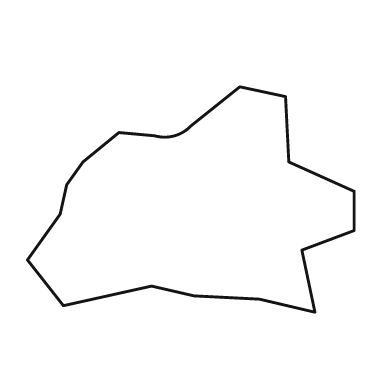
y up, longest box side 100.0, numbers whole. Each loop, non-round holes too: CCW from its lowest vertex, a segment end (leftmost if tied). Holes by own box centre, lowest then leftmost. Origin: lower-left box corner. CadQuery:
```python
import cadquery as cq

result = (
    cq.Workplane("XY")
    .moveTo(88.0, 0.0)
    .lineTo(84.0, 19.0)
    .lineTo(100.0, 25.0)
    .lineTo(100.0, 37.0)
    .lineTo(80.0, 46.0)
    .lineTo(79.0, 66.0)
    .lineTo(65.0, 69.0)
    .lineTo(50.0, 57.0)
    .threePointArc((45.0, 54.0), (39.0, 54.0))
    .lineTo(28.0, 55.0)
    .lineTo(17.0, 46.0)
    .lineTo(12.0, 39.0)
    .lineTo(10.0, 30.0)
    .lineTo(0.0, 16.0)
    .lineTo(11.0, 2.0)
    .lineTo(38.0, 8.0)
    .lineTo(51.0, 5.0)
    .lineTo(71.0, 4.0)
    .close()
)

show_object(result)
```